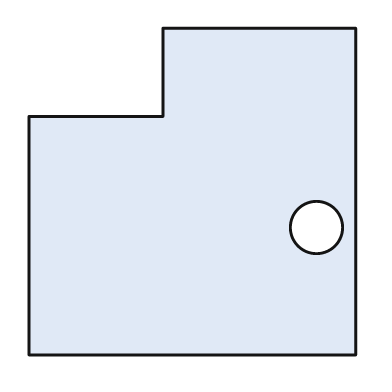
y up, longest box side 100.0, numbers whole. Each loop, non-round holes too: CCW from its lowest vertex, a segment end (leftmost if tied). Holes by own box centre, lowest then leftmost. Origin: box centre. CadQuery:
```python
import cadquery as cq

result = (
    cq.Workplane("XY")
    .moveTo(-50.0, -50.0)
    .lineTo(50.0, -50.0)
    .lineTo(50.0, 50.0)
    .lineTo(-9.0, 50.0)
    .lineTo(-9.0, 23.0)
    .lineTo(-50.0, 23.0)
    .close()
    .moveTo(38.0, -11.0)
    .circle(8.0)
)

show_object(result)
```